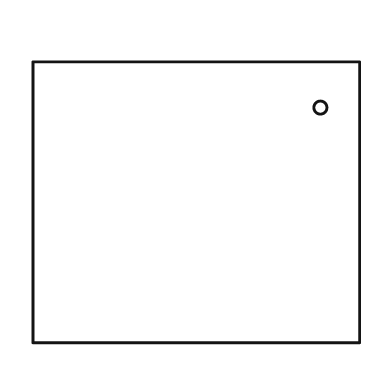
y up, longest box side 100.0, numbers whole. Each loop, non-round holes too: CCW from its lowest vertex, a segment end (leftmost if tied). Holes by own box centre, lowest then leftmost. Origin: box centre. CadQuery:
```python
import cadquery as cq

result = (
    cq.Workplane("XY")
    .moveTo(-50.0, -43.0)
    .lineTo(50.0, -43.0)
    .lineTo(50.0, 43.0)
    .lineTo(-50.0, 43.0)
    .close()
    .moveTo(38.0, 29.0)
    .circle(2.0)
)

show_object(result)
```